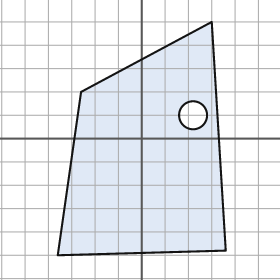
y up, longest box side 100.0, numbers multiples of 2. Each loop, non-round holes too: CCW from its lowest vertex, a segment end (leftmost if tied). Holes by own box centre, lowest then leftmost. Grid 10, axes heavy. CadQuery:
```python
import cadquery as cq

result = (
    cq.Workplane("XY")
    .moveTo(-36.0, -50.0)
    .lineTo(36.0, -48.0)
    .lineTo(30.0, 50.0)
    .lineTo(-26.0, 20.0)
    .close()
    .moveTo(22.0, 10.0)
    .circle(6.0)
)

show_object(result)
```